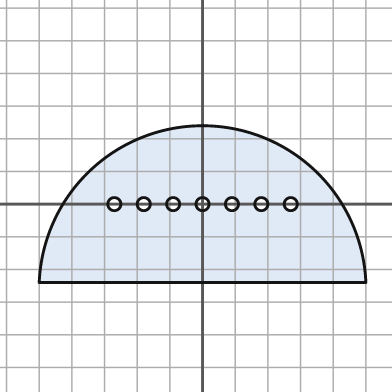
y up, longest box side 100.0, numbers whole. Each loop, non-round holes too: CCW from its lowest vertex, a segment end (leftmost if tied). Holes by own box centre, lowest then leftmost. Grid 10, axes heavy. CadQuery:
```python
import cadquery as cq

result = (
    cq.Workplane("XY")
    .moveTo(-50.0, -24.0)
    .lineTo(50.0, -24.0)
    .threePointArc((0.0, 24.0), (-50.0, -24.0))
    .close()
    .moveTo(-27.0, 0.0)
    .circle(2.0)
    .moveTo(-18.0, 0.0)
    .circle(2.0)
    .moveTo(-9.0, 0.0)
    .circle(2.0)
    .moveTo(0.0, 0.0)
    .circle(2.0)
    .moveTo(9.0, 0.0)
    .circle(2.0)
    .moveTo(18.0, 0.0)
    .circle(2.0)
    .moveTo(27.0, 0.0)
    .circle(2.0)
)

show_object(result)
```